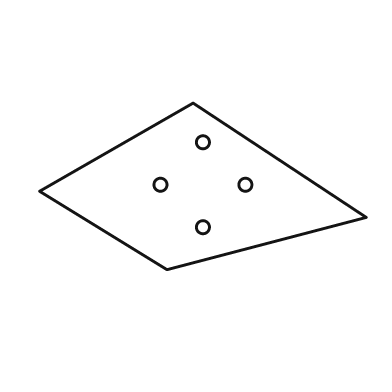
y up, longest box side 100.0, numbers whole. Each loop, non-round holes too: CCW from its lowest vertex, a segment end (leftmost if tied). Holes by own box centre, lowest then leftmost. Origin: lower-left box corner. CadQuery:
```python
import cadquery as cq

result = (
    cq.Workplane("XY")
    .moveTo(39.0, 0.0)
    .lineTo(100.0, 16.0)
    .lineTo(47.0, 51.0)
    .lineTo(0.0, 24.0)
    .close()
    .moveTo(50.0, 13.0)
    .circle(2.0)
    .moveTo(37.0, 26.0)
    .circle(2.0)
    .moveTo(63.0, 26.0)
    .circle(2.0)
    .moveTo(50.0, 39.0)
    .circle(2.0)
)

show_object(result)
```